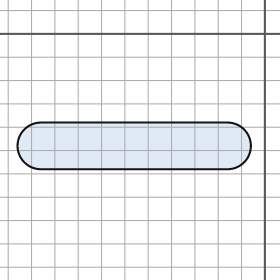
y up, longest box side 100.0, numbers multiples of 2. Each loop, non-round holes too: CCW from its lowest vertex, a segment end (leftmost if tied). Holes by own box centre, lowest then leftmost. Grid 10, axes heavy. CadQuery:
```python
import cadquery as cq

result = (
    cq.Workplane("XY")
    .moveTo(-96.0, -58.0)
    .lineTo(-16.0, -58.0)
    .threePointArc((-6.0, -48.0), (-16.0, -38.0))
    .lineTo(-96.0, -38.0)
    .threePointArc((-106.0, -48.0), (-96.0, -58.0))
    .close()
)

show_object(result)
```